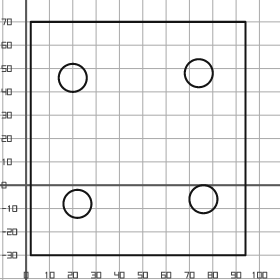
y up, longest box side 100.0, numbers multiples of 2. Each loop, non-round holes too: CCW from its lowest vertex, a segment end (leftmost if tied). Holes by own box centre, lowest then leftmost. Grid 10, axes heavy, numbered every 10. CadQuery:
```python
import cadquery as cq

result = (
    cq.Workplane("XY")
    .moveTo(2.0, -30.0)
    .lineTo(94.0, -30.0)
    .lineTo(94.0, 70.0)
    .lineTo(2.0, 70.0)
    .close()
    .moveTo(22.0, -8.0)
    .circle(6.0)
    .moveTo(76.0, -6.0)
    .circle(6.0)
    .moveTo(20.0, 46.0)
    .circle(6.0)
    .moveTo(74.0, 48.0)
    .circle(6.0)
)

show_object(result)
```